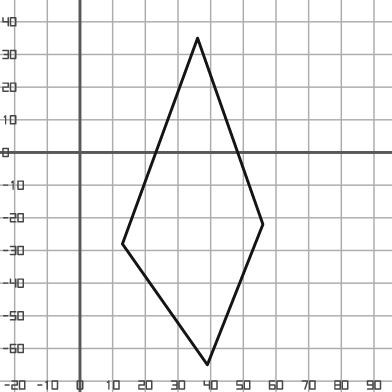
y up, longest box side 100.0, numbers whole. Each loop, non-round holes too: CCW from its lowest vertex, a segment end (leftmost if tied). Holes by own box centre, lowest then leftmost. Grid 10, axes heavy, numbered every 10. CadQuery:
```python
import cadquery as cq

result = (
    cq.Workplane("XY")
    .moveTo(39.0, -65.0)
    .lineTo(56.0, -22.0)
    .lineTo(36.0, 35.0)
    .lineTo(13.0, -28.0)
    .close()
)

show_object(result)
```